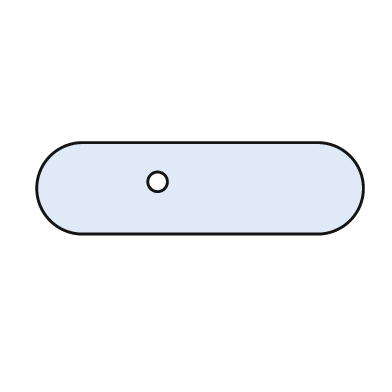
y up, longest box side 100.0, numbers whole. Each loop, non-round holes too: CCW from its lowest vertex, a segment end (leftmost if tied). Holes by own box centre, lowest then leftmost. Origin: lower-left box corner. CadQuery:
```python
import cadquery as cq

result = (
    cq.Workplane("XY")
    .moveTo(14.0, 0.0)
    .lineTo(86.0, 0.0)
    .threePointArc((100.0, 14.0), (86.0, 28.0))
    .lineTo(14.0, 28.0)
    .threePointArc((0.0, 14.0), (14.0, 0.0))
    .close()
    .moveTo(37.0, 16.0)
    .circle(3.0)
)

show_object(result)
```